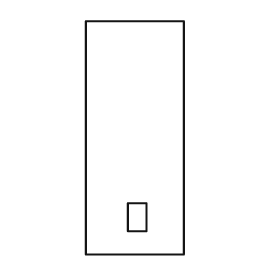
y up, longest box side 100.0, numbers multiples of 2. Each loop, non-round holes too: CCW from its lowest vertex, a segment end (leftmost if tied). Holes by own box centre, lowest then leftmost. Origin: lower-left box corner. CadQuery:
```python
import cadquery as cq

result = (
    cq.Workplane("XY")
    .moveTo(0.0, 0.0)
    .lineTo(42.0, 0.0)
    .lineTo(42.0, 100.0)
    .lineTo(0.0, 100.0)
    .close()
    .moveTo(18.0, 10.0)
    .lineTo(26.0, 10.0)
    .lineTo(26.0, 22.0)
    .lineTo(18.0, 22.0)
    .close()
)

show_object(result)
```